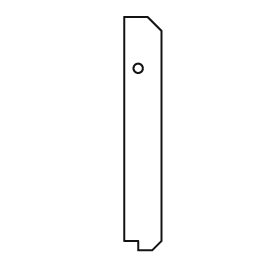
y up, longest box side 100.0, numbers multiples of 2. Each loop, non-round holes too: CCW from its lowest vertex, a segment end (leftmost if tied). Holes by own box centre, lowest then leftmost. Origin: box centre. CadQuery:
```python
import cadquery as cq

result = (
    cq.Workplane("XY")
    .moveTo(-2.0, -50.0)
    .lineTo(4.0, -50.0)
    .lineTo(8.0, -46.0)
    .lineTo(8.0, 44.0)
    .lineTo(2.0, 50.0)
    .lineTo(-8.0, 50.0)
    .lineTo(-8.0, -46.0)
    .lineTo(-2.0, -46.0)
    .close()
    .moveTo(-2.0, 28.0)
    .circle(2.0)
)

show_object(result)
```